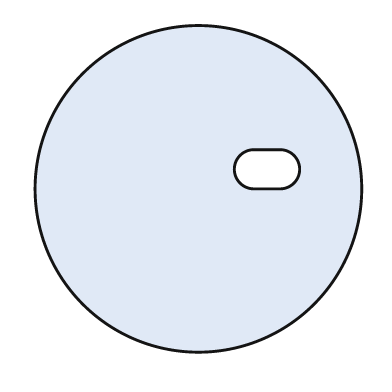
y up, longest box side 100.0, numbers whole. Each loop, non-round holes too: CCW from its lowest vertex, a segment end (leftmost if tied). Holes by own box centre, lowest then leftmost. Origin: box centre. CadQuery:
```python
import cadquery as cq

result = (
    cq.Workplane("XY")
    .moveTo(0.0, 0.0)
    .circle(50.0)
    .moveTo(17.0, 0.0)
    .lineTo(25.0, 0.0)
    .threePointArc((31.0, 6.0), (25.0, 12.0))
    .lineTo(17.0, 12.0)
    .threePointArc((11.0, 6.0), (17.0, 0.0))
    .close()
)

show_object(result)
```